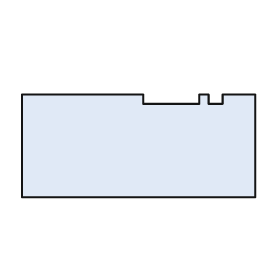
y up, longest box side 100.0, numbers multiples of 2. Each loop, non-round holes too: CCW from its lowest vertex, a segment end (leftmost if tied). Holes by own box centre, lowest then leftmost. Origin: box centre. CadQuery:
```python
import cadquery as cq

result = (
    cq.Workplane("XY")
    .moveTo(-50.0, -22.0)
    .lineTo(50.0, -22.0)
    .lineTo(50.0, 22.0)
    .lineTo(36.0, 22.0)
    .lineTo(36.0, 18.0)
    .lineTo(30.0, 18.0)
    .lineTo(30.0, 22.0)
    .lineTo(26.0, 22.0)
    .lineTo(26.0, 18.0)
    .lineTo(2.0, 18.0)
    .lineTo(2.0, 22.0)
    .lineTo(-50.0, 22.0)
    .close()
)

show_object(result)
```